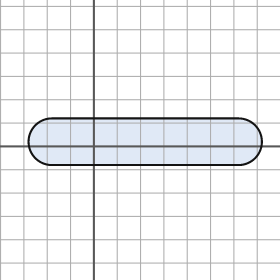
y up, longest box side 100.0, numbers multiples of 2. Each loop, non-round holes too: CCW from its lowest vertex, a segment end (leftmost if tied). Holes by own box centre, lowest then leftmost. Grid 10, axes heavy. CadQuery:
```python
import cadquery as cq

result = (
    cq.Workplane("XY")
    .moveTo(-18.0, -8.0)
    .lineTo(62.0, -8.0)
    .threePointArc((72.0, 2.0), (62.0, 12.0))
    .lineTo(-18.0, 12.0)
    .threePointArc((-28.0, 2.0), (-18.0, -8.0))
    .close()
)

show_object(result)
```